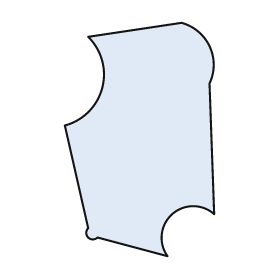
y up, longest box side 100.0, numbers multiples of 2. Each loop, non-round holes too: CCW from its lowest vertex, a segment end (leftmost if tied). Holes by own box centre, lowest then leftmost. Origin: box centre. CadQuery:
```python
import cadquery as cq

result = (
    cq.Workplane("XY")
    .moveTo(12.0, -50.0)
    .threePointArc((14.0, -32.0), (32.0, -32.0))
    .lineTo(30.0, 24.0)
    .threePointArc((30.0, 40.0), (18.0, 50.0))
    .lineTo(-22.0, 44.0)
    .threePointArc((-16.0, 22.0), (-32.0, 6.0))
    .lineTo(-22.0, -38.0)
    .threePointArc((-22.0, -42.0), (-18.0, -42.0))
    .close()
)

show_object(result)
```